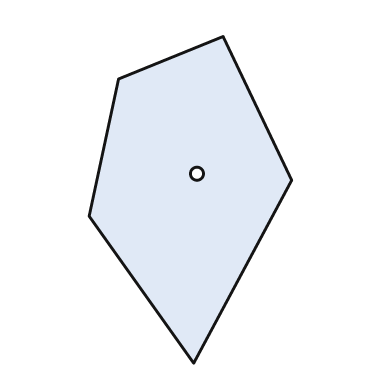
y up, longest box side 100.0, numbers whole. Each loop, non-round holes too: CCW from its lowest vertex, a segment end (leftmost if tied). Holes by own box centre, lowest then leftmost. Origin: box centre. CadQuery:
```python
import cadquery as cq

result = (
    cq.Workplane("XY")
    .moveTo(1.0, -50.0)
    .lineTo(31.0, 6.0)
    .lineTo(10.0, 50.0)
    .lineTo(-22.0, 37.0)
    .lineTo(-31.0, -5.0)
    .close()
    .moveTo(2.0, 8.0)
    .circle(2.0)
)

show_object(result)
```